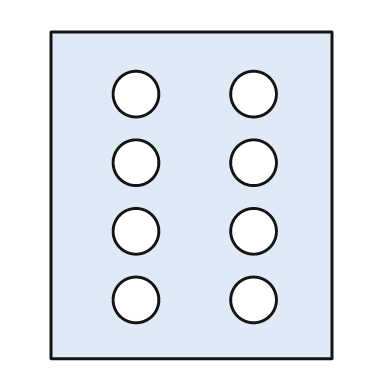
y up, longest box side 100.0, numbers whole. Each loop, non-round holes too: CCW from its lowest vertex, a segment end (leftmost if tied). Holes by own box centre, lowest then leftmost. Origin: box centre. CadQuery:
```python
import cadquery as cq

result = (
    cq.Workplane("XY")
    .moveTo(-43.0, -50.0)
    .lineTo(43.0, -50.0)
    .lineTo(43.0, 50.0)
    .lineTo(-43.0, 50.0)
    .close()
    .moveTo(-17.0, -32.0)
    .circle(7.0)
    .moveTo(19.0, -32.0)
    .circle(7.0)
    .moveTo(-17.0, -11.0)
    .circle(7.0)
    .moveTo(19.0, -11.0)
    .circle(7.0)
    .moveTo(-17.0, 10.0)
    .circle(7.0)
    .moveTo(19.0, 10.0)
    .circle(7.0)
    .moveTo(-17.0, 31.0)
    .circle(7.0)
    .moveTo(19.0, 31.0)
    .circle(7.0)
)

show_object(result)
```